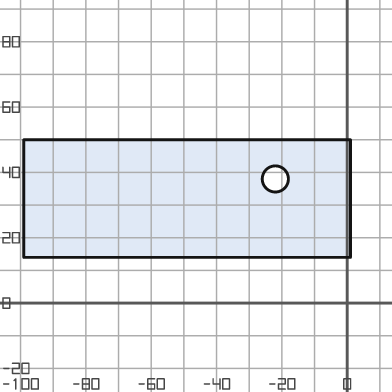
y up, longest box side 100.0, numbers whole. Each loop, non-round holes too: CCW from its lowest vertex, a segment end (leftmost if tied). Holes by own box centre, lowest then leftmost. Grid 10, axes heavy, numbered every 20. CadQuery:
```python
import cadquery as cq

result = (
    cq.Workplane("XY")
    .moveTo(-99.0, 14.0)
    .lineTo(1.0, 14.0)
    .lineTo(1.0, 50.0)
    .lineTo(-99.0, 50.0)
    .close()
    .moveTo(-22.0, 38.0)
    .circle(4.0)
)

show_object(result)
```